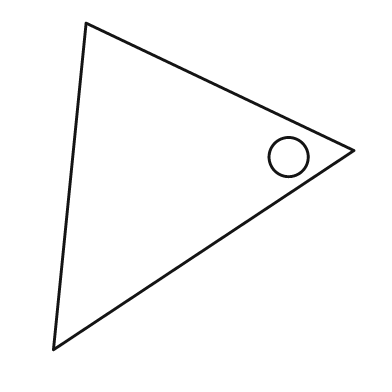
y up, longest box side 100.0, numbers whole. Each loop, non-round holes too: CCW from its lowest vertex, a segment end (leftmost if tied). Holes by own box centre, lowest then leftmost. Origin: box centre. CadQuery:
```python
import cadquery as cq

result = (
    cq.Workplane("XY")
    .moveTo(-46.0, -50.0)
    .lineTo(46.0, 11.0)
    .lineTo(-36.0, 50.0)
    .close()
    .moveTo(26.0, 9.0)
    .circle(6.0)
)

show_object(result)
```